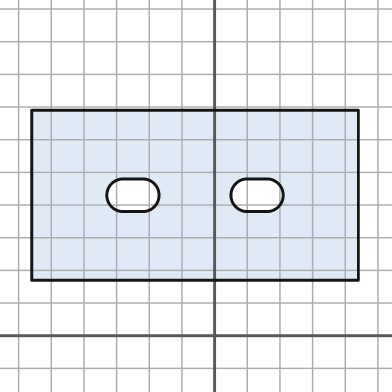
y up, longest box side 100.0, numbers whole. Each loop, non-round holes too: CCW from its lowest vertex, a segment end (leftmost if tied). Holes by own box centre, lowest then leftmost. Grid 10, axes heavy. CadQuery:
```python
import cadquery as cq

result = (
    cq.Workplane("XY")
    .moveTo(-56.0, 17.0)
    .lineTo(44.0, 17.0)
    .lineTo(44.0, 69.0)
    .lineTo(-56.0, 69.0)
    .close()
    .moveTo(-28.0, 38.0)
    .lineTo(-22.0, 38.0)
    .threePointArc((-17.0, 43.0), (-22.0, 48.0))
    .lineTo(-28.0, 48.0)
    .threePointArc((-33.0, 43.0), (-28.0, 38.0))
    .close()
    .moveTo(10.0, 38.0)
    .lineTo(16.0, 38.0)
    .threePointArc((21.0, 43.0), (16.0, 48.0))
    .lineTo(10.0, 48.0)
    .threePointArc((5.0, 43.0), (10.0, 38.0))
    .close()
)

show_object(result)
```